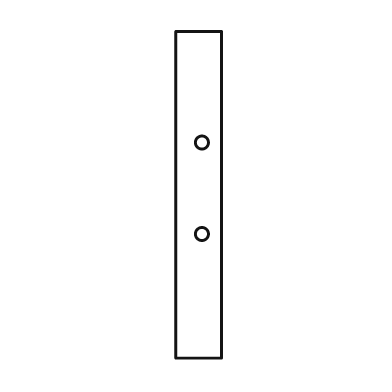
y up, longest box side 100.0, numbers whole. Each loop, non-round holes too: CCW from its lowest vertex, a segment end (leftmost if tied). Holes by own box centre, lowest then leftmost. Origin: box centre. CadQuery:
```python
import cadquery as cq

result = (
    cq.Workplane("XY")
    .moveTo(-7.0, -50.0)
    .lineTo(7.0, -50.0)
    .lineTo(7.0, 50.0)
    .lineTo(-7.0, 50.0)
    .close()
    .moveTo(1.0, -12.0)
    .circle(2.0)
    .moveTo(1.0, 16.0)
    .circle(2.0)
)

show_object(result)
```